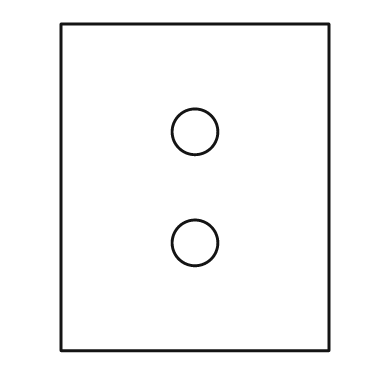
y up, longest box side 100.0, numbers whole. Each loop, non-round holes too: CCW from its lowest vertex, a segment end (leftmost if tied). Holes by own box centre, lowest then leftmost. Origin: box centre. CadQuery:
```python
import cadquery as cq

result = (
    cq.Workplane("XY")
    .moveTo(-41.0, -50.0)
    .lineTo(41.0, -50.0)
    .lineTo(41.0, 50.0)
    .lineTo(-41.0, 50.0)
    .close()
    .moveTo(0.0, -17.0)
    .circle(7.0)
    .moveTo(0.0, 17.0)
    .circle(7.0)
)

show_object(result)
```